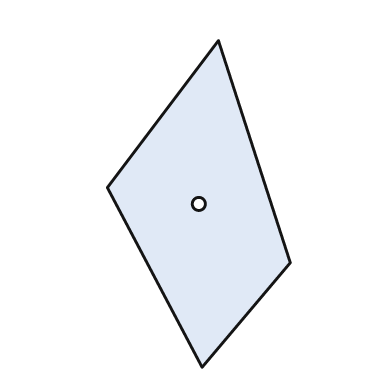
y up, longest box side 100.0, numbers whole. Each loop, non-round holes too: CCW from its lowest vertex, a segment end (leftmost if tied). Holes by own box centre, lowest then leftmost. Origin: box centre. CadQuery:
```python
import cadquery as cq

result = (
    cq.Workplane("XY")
    .moveTo(1.0, -50.0)
    .lineTo(28.0, -18.0)
    .lineTo(6.0, 50.0)
    .lineTo(-28.0, 5.0)
    .close()
    .moveTo(0.0, 0.0)
    .circle(2.0)
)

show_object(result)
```